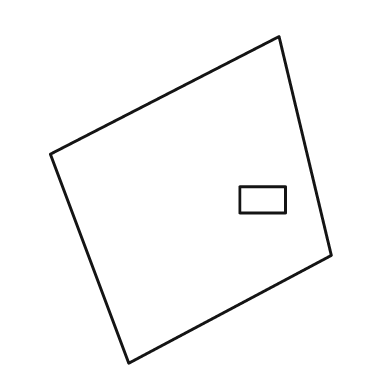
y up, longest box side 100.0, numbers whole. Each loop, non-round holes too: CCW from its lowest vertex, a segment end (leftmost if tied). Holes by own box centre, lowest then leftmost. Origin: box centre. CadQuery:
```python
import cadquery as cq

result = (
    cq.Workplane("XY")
    .moveTo(-19.0, -50.0)
    .lineTo(43.0, -17.0)
    .lineTo(27.0, 50.0)
    .lineTo(-43.0, 14.0)
    .close()
    .moveTo(15.0, -4.0)
    .lineTo(29.0, -4.0)
    .lineTo(29.0, 4.0)
    .lineTo(15.0, 4.0)
    .close()
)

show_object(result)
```